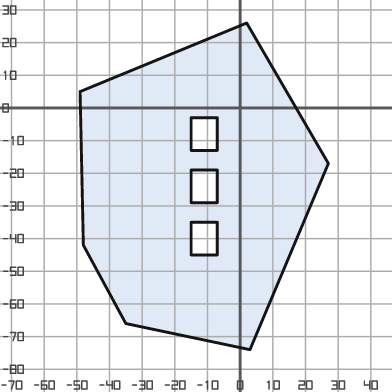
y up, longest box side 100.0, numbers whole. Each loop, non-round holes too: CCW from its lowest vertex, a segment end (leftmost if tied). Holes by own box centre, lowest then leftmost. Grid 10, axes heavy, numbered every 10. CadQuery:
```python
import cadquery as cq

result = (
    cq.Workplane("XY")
    .moveTo(3.0, -74.0)
    .lineTo(27.0, -17.0)
    .lineTo(2.0, 26.0)
    .lineTo(-49.0, 5.0)
    .lineTo(-48.0, -42.0)
    .lineTo(-35.0, -66.0)
    .close()
    .moveTo(-15.0, -45.0)
    .lineTo(-7.0, -45.0)
    .lineTo(-7.0, -35.0)
    .lineTo(-15.0, -35.0)
    .close()
    .moveTo(-15.0, -29.0)
    .lineTo(-7.0, -29.0)
    .lineTo(-7.0, -19.0)
    .lineTo(-15.0, -19.0)
    .close()
    .moveTo(-15.0, -13.0)
    .lineTo(-7.0, -13.0)
    .lineTo(-7.0, -3.0)
    .lineTo(-15.0, -3.0)
    .close()
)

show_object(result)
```